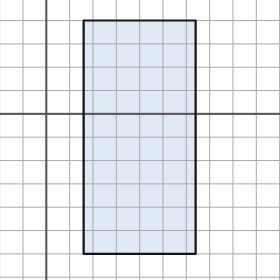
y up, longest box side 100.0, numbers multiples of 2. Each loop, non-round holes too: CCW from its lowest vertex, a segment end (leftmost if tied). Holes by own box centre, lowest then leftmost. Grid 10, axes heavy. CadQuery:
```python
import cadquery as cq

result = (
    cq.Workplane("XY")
    .moveTo(16.0, -60.0)
    .lineTo(64.0, -60.0)
    .lineTo(64.0, 40.0)
    .lineTo(16.0, 40.0)
    .close()
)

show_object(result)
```